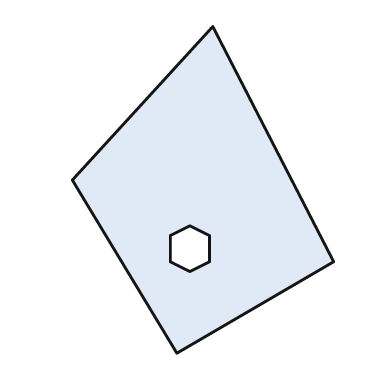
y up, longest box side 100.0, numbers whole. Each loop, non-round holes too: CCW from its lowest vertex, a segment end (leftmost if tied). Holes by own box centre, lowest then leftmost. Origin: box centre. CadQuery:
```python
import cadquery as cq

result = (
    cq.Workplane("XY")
    .moveTo(-8.0, -50.0)
    .lineTo(40.0, -22.0)
    .lineTo(3.0, 50.0)
    .lineTo(-40.0, 3.0)
    .close()
    .moveTo(-4.0, -25.0)
    .lineTo(2.0, -22.0)
    .lineTo(2.0, -14.0)
    .lineTo(-4.0, -11.0)
    .lineTo(-10.0, -14.0)
    .lineTo(-10.0, -22.0)
    .close()
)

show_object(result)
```